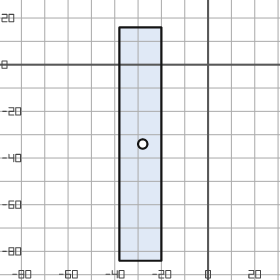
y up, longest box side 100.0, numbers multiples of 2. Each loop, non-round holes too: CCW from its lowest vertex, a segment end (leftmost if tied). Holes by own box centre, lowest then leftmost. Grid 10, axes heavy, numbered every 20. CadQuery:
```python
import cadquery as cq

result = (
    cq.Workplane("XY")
    .moveTo(-38.0, -84.0)
    .lineTo(-20.0, -84.0)
    .lineTo(-20.0, 16.0)
    .lineTo(-38.0, 16.0)
    .close()
    .moveTo(-28.0, -34.0)
    .circle(2.0)
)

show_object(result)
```